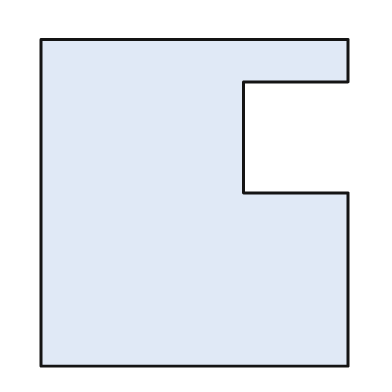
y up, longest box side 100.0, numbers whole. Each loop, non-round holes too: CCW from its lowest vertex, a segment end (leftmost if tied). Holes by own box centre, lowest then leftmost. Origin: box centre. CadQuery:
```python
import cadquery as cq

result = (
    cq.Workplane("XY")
    .moveTo(-47.0, -50.0)
    .lineTo(47.0, -50.0)
    .lineTo(47.0, 3.0)
    .lineTo(15.0, 3.0)
    .lineTo(15.0, 37.0)
    .lineTo(47.0, 37.0)
    .lineTo(47.0, 50.0)
    .lineTo(-47.0, 50.0)
    .close()
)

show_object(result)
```